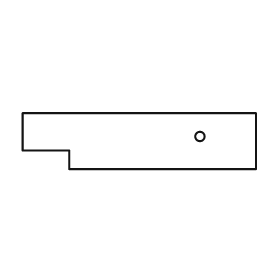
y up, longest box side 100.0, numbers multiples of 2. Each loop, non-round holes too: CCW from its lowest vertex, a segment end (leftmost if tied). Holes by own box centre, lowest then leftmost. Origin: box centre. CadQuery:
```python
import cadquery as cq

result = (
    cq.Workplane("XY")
    .moveTo(-30.0, -12.0)
    .lineTo(50.0, -12.0)
    .lineTo(50.0, 12.0)
    .lineTo(-50.0, 12.0)
    .lineTo(-50.0, -4.0)
    .lineTo(-30.0, -4.0)
    .close()
    .moveTo(26.0, 2.0)
    .circle(2.0)
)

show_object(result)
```